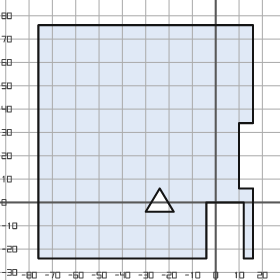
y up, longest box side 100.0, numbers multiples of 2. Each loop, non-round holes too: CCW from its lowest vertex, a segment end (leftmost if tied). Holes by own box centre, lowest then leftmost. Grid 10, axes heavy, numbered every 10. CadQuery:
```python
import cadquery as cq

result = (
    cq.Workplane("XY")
    .moveTo(-76.0, -24.0)
    .lineTo(-4.0, -24.0)
    .lineTo(-4.0, 0.0)
    .lineTo(12.0, 0.0)
    .lineTo(12.0, -24.0)
    .lineTo(16.0, -24.0)
    .lineTo(16.0, 6.0)
    .lineTo(10.0, 6.0)
    .lineTo(10.0, 34.0)
    .lineTo(16.0, 34.0)
    .lineTo(16.0, 76.0)
    .lineTo(-76.0, 76.0)
    .close()
    .moveTo(-30.0, -4.0)
    .lineTo(-18.0, -4.0)
    .lineTo(-24.0, 6.0)
    .close()
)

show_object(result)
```